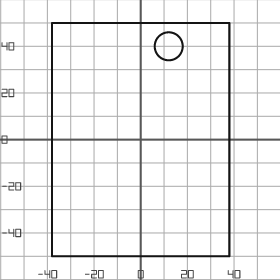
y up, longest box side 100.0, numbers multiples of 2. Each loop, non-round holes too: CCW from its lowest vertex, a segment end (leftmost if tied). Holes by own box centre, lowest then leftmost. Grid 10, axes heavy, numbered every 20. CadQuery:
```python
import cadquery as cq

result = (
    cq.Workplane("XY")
    .moveTo(-38.0, -50.0)
    .lineTo(38.0, -50.0)
    .lineTo(38.0, 50.0)
    .lineTo(-38.0, 50.0)
    .close()
    .moveTo(12.0, 40.0)
    .circle(6.0)
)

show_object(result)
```